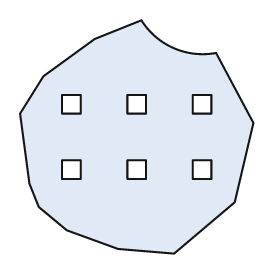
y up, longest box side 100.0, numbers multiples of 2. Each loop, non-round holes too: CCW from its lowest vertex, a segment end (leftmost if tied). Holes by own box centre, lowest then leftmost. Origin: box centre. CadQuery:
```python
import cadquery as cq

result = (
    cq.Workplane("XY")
    .moveTo(16.0, -50.0)
    .lineTo(42.0, -28.0)
    .lineTo(50.0, 6.0)
    .lineTo(34.0, 36.0)
    .threePointArc((16.0, 38.0), (2.0, 50.0))
    .lineTo(-18.0, 42.0)
    .lineTo(-40.0, 26.0)
    .lineTo(-50.0, 10.0)
    .lineTo(-46.0, -20.0)
    .lineTo(-42.0, -30.0)
    .lineTo(-30.0, -40.0)
    .lineTo(-8.0, -48.0)
    .close()
    .moveTo(-32.0, -18.0)
    .lineTo(-24.0, -18.0)
    .lineTo(-24.0, -10.0)
    .lineTo(-32.0, -10.0)
    .close()
    .moveTo(-4.0, -18.0)
    .lineTo(4.0, -18.0)
    .lineTo(4.0, -10.0)
    .lineTo(-4.0, -10.0)
    .close()
    .moveTo(24.0, -18.0)
    .lineTo(32.0, -18.0)
    .lineTo(32.0, -10.0)
    .lineTo(24.0, -10.0)
    .close()
    .moveTo(-32.0, 10.0)
    .lineTo(-24.0, 10.0)
    .lineTo(-24.0, 18.0)
    .lineTo(-32.0, 18.0)
    .close()
    .moveTo(-4.0, 10.0)
    .lineTo(4.0, 10.0)
    .lineTo(4.0, 18.0)
    .lineTo(-4.0, 18.0)
    .close()
    .moveTo(24.0, 10.0)
    .lineTo(32.0, 10.0)
    .lineTo(32.0, 18.0)
    .lineTo(24.0, 18.0)
    .close()
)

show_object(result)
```